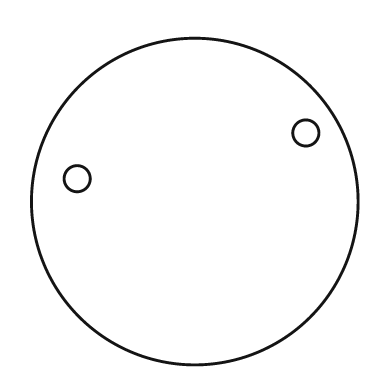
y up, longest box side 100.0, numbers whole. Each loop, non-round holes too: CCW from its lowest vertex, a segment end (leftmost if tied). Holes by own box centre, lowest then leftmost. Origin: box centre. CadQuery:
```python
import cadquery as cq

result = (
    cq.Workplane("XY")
    .moveTo(0.0, 0.0)
    .circle(50.0)
    .moveTo(-36.0, 7.0)
    .circle(4.0)
    .moveTo(34.0, 21.0)
    .circle(4.0)
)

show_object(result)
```